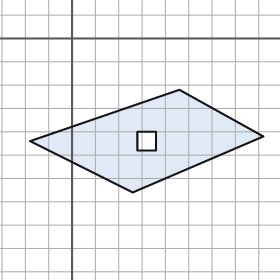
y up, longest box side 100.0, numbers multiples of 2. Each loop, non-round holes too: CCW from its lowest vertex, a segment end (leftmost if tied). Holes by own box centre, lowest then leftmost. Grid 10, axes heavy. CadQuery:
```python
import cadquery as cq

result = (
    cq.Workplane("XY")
    .moveTo(26.0, -66.0)
    .lineTo(82.0, -42.0)
    .lineTo(46.0, -22.0)
    .lineTo(-18.0, -44.0)
    .close()
    .moveTo(28.0, -48.0)
    .lineTo(36.0, -48.0)
    .lineTo(36.0, -40.0)
    .lineTo(28.0, -40.0)
    .close()
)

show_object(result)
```